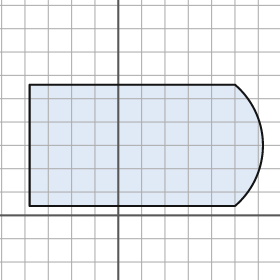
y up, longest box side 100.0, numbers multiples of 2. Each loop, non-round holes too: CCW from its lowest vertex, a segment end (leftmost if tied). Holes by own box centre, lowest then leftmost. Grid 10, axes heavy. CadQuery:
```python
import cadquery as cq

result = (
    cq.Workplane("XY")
    .moveTo(-38.0, 4.0)
    .lineTo(50.0, 4.0)
    .threePointArc((62.0, 30.0), (50.0, 56.0))
    .lineTo(-38.0, 56.0)
    .close()
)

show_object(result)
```